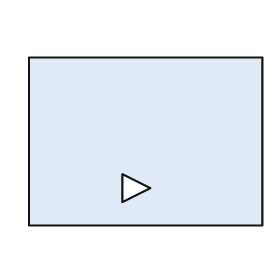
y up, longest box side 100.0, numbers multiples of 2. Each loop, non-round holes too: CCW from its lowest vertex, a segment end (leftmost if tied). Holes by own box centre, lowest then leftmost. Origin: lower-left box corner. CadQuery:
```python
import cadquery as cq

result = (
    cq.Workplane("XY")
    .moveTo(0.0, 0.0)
    .lineTo(100.0, 0.0)
    .lineTo(100.0, 72.0)
    .lineTo(0.0, 72.0)
    .close()
    .moveTo(40.0, 10.0)
    .lineTo(52.0, 16.0)
    .lineTo(40.0, 22.0)
    .close()
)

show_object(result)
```